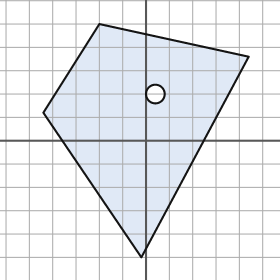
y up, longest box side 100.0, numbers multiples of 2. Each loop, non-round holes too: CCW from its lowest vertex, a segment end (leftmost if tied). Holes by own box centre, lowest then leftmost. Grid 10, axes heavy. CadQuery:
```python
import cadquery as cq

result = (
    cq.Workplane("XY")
    .moveTo(-2.0, -50.0)
    .lineTo(44.0, 36.0)
    .lineTo(-20.0, 50.0)
    .lineTo(-44.0, 12.0)
    .close()
    .moveTo(4.0, 20.0)
    .circle(4.0)
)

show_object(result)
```